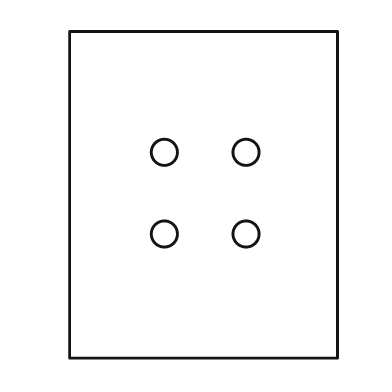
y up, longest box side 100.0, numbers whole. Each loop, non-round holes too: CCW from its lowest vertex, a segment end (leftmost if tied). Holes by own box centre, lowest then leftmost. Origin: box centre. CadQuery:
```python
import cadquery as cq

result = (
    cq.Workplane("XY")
    .moveTo(-41.0, -50.0)
    .lineTo(41.0, -50.0)
    .lineTo(41.0, 50.0)
    .lineTo(-41.0, 50.0)
    .close()
    .moveTo(-12.0, -12.0)
    .circle(4.0)
    .moveTo(13.0, -12.0)
    .circle(4.0)
    .moveTo(-12.0, 13.0)
    .circle(4.0)
    .moveTo(13.0, 13.0)
    .circle(4.0)
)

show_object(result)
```